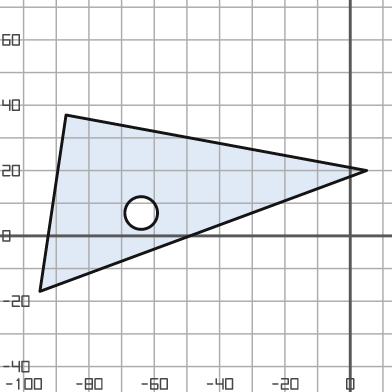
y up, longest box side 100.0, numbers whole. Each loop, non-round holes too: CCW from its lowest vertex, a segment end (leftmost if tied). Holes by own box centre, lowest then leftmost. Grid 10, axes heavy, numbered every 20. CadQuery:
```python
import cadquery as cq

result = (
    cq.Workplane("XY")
    .moveTo(-95.0, -17.0)
    .lineTo(5.0, 20.0)
    .lineTo(-87.0, 37.0)
    .close()
    .moveTo(-64.0, 7.0)
    .circle(5.0)
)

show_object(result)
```